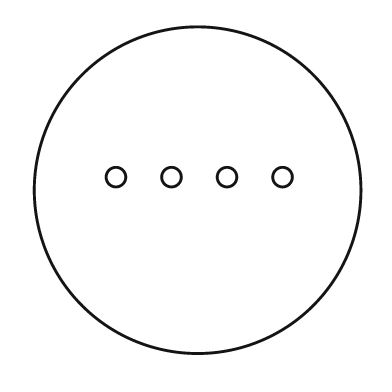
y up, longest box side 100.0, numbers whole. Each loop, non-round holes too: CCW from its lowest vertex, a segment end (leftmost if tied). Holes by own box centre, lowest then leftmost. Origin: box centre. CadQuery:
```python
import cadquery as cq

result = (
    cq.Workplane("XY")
    .moveTo(0.0, 0.0)
    .circle(50.0)
    .moveTo(-25.0, 4.0)
    .circle(3.0)
    .moveTo(-8.0, 4.0)
    .circle(3.0)
    .moveTo(9.0, 4.0)
    .circle(3.0)
    .moveTo(26.0, 4.0)
    .circle(3.0)
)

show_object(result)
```